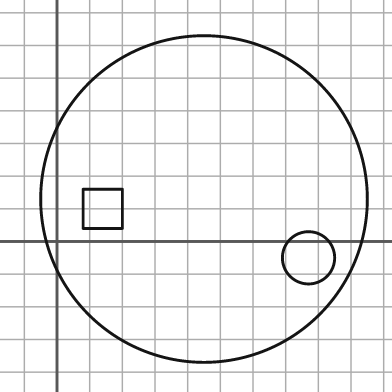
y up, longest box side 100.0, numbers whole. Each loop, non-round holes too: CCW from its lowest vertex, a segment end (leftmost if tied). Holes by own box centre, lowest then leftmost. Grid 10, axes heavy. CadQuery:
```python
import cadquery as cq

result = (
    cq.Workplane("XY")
    .moveTo(45.0, 13.0)
    .circle(50.0)
    .moveTo(77.0, -5.0)
    .circle(8.0)
    .moveTo(8.0, 4.0)
    .lineTo(20.0, 4.0)
    .lineTo(20.0, 16.0)
    .lineTo(8.0, 16.0)
    .close()
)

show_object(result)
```